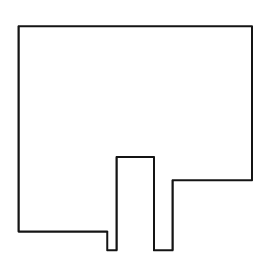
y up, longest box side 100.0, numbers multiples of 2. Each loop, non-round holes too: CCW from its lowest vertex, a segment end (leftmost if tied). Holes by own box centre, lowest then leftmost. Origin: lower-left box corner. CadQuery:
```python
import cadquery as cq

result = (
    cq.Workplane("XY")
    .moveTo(38.0, 0.0)
    .lineTo(42.0, 0.0)
    .lineTo(42.0, 40.0)
    .lineTo(58.0, 40.0)
    .lineTo(58.0, 0.0)
    .lineTo(66.0, 0.0)
    .lineTo(66.0, 30.0)
    .lineTo(100.0, 30.0)
    .lineTo(100.0, 96.0)
    .lineTo(0.0, 96.0)
    .lineTo(0.0, 8.0)
    .lineTo(38.0, 8.0)
    .close()
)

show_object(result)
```